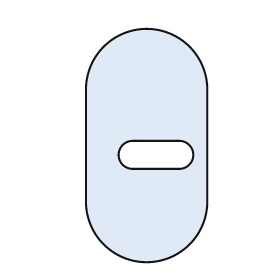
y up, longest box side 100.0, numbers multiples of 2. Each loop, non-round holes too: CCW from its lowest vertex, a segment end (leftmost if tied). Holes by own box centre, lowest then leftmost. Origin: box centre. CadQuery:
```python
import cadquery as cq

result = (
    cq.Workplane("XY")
    .moveTo(-26.0, -24.0)
    .threePointArc((0.0, -50.0), (26.0, -24.0))
    .lineTo(26.0, 24.0)
    .threePointArc((0.0, 50.0), (-26.0, 24.0))
    .close()
    .moveTo(-6.0, -10.0)
    .lineTo(14.0, -10.0)
    .threePointArc((20.0, -4.0), (14.0, 2.0))
    .lineTo(-6.0, 2.0)
    .threePointArc((-12.0, -4.0), (-6.0, -10.0))
    .close()
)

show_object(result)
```